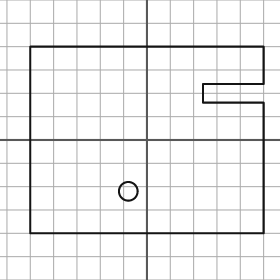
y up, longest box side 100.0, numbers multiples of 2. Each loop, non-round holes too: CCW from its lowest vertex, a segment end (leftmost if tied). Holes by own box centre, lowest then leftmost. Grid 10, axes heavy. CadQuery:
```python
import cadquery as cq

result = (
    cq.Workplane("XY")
    .moveTo(-50.0, -40.0)
    .lineTo(50.0, -40.0)
    .lineTo(50.0, 16.0)
    .lineTo(24.0, 16.0)
    .lineTo(24.0, 24.0)
    .lineTo(50.0, 24.0)
    .lineTo(50.0, 40.0)
    .lineTo(-50.0, 40.0)
    .close()
    .moveTo(-8.0, -22.0)
    .circle(4.0)
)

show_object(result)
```